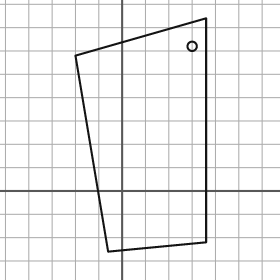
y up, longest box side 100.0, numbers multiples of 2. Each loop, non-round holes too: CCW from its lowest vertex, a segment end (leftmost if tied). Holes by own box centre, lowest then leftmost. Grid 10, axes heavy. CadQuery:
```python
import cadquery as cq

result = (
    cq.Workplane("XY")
    .moveTo(-6.0, -26.0)
    .lineTo(36.0, -22.0)
    .lineTo(36.0, 74.0)
    .lineTo(-20.0, 58.0)
    .close()
    .moveTo(30.0, 62.0)
    .circle(2.0)
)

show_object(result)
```